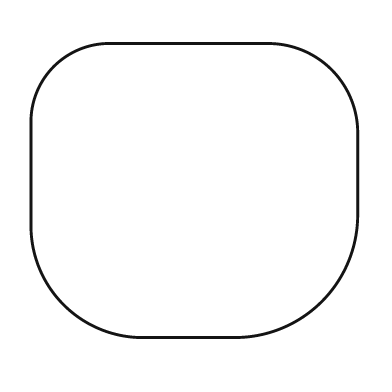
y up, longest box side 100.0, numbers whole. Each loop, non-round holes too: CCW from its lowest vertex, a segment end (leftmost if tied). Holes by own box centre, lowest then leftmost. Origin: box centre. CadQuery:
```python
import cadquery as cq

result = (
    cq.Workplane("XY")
    .moveTo(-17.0, -45.0)
    .lineTo(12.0, -45.0)
    .threePointArc((39.0, -34.0), (50.0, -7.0))
    .lineTo(50.0, 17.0)
    .threePointArc((42.0, 37.0), (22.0, 45.0))
    .lineTo(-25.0, 45.0)
    .threePointArc((-43.0, 38.0), (-50.0, 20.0))
    .lineTo(-50.0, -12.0)
    .threePointArc((-40.0, -35.0), (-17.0, -45.0))
    .close()
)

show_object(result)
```